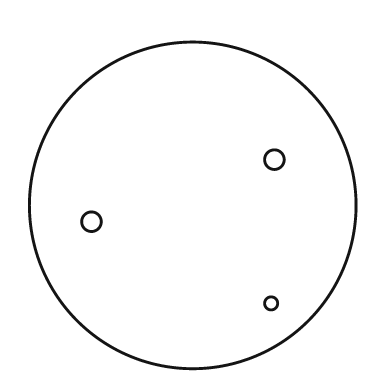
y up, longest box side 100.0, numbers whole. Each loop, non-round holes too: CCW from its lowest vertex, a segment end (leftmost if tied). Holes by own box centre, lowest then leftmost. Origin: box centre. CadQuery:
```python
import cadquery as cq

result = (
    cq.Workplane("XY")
    .moveTo(0.0, 0.0)
    .circle(50.0)
    .moveTo(24.0, -30.0)
    .circle(2.0)
    .moveTo(-31.0, -5.0)
    .circle(3.0)
    .moveTo(25.0, 14.0)
    .circle(3.0)
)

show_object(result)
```